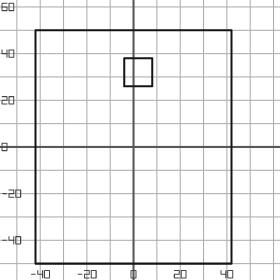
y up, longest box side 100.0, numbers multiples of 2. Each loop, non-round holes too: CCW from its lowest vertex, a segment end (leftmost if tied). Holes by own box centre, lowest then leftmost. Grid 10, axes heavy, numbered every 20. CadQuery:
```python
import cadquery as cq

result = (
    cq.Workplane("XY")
    .moveTo(-42.0, -50.0)
    .lineTo(42.0, -50.0)
    .lineTo(42.0, 50.0)
    .lineTo(-42.0, 50.0)
    .close()
    .moveTo(-4.0, 26.0)
    .lineTo(8.0, 26.0)
    .lineTo(8.0, 38.0)
    .lineTo(-4.0, 38.0)
    .close()
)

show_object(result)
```